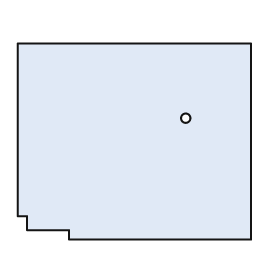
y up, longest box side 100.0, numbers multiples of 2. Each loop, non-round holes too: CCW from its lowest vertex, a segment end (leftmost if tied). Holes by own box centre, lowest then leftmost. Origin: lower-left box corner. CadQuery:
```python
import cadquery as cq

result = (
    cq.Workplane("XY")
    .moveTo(22.0, 0.0)
    .lineTo(100.0, 0.0)
    .lineTo(100.0, 84.0)
    .lineTo(0.0, 84.0)
    .lineTo(0.0, 10.0)
    .lineTo(4.0, 10.0)
    .lineTo(4.0, 4.0)
    .lineTo(22.0, 4.0)
    .close()
    .moveTo(72.0, 52.0)
    .circle(2.0)
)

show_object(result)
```